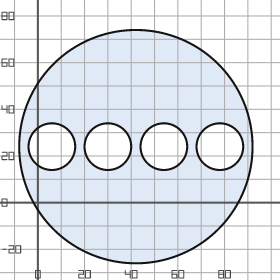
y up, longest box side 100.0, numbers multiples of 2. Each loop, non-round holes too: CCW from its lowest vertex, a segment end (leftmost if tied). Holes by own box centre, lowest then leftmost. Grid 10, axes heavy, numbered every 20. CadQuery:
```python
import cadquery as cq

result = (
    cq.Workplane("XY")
    .moveTo(42.0, 24.0)
    .circle(50.0)
    .moveTo(6.0, 24.0)
    .circle(10.0)
    .moveTo(30.0, 24.0)
    .circle(10.0)
    .moveTo(54.0, 24.0)
    .circle(10.0)
    .moveTo(78.0, 24.0)
    .circle(10.0)
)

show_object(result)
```